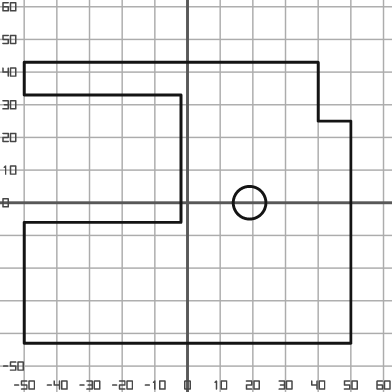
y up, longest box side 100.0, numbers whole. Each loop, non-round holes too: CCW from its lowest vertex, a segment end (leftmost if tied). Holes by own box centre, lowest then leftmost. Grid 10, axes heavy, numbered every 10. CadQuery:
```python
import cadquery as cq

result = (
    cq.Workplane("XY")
    .moveTo(-50.0, -43.0)
    .lineTo(50.0, -43.0)
    .lineTo(50.0, 25.0)
    .lineTo(40.0, 25.0)
    .lineTo(40.0, 43.0)
    .lineTo(-50.0, 43.0)
    .lineTo(-50.0, 33.0)
    .lineTo(-2.0, 33.0)
    .lineTo(-2.0, -6.0)
    .lineTo(-50.0, -6.0)
    .close()
    .moveTo(19.0, 0.0)
    .circle(5.0)
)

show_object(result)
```